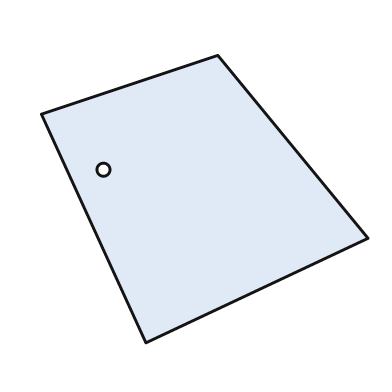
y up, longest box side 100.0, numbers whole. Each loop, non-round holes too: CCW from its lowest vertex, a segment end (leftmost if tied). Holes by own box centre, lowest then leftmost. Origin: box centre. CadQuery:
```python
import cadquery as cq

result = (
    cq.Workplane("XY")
    .moveTo(-18.0, -44.0)
    .lineTo(50.0, -12.0)
    .lineTo(4.0, 44.0)
    .lineTo(-50.0, 26.0)
    .close()
    .moveTo(-31.0, 9.0)
    .circle(2.0)
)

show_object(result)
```